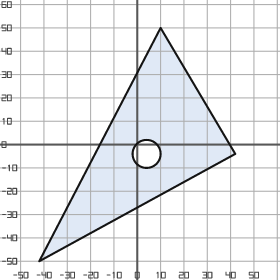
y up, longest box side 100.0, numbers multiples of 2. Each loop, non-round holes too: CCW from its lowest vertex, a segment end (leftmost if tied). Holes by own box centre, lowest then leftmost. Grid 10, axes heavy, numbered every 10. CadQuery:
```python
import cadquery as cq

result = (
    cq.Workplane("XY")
    .moveTo(-42.0, -50.0)
    .lineTo(42.0, -4.0)
    .lineTo(10.0, 50.0)
    .close()
    .moveTo(4.0, -4.0)
    .circle(6.0)
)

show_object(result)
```